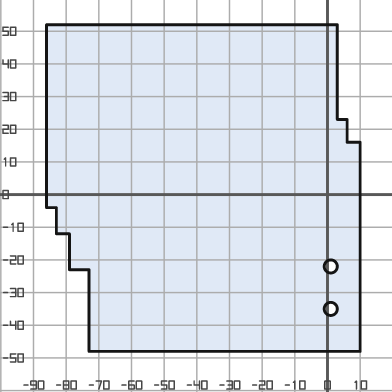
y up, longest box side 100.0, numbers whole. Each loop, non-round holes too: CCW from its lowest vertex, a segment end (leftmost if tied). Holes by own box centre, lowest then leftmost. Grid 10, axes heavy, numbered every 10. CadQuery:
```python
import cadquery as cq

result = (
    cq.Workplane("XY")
    .moveTo(-73.0, -48.0)
    .lineTo(10.0, -48.0)
    .lineTo(10.0, 16.0)
    .lineTo(6.0, 16.0)
    .lineTo(6.0, 23.0)
    .lineTo(3.0, 23.0)
    .lineTo(3.0, 52.0)
    .lineTo(-86.0, 52.0)
    .lineTo(-86.0, -4.0)
    .lineTo(-83.0, -4.0)
    .lineTo(-83.0, -12.0)
    .lineTo(-79.0, -12.0)
    .lineTo(-79.0, -23.0)
    .lineTo(-73.0, -23.0)
    .close()
    .moveTo(1.0, -35.0)
    .circle(2.0)
    .moveTo(1.0, -22.0)
    .circle(2.0)
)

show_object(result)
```